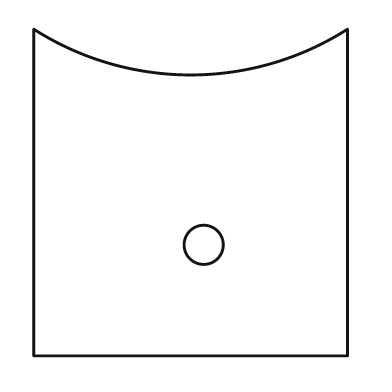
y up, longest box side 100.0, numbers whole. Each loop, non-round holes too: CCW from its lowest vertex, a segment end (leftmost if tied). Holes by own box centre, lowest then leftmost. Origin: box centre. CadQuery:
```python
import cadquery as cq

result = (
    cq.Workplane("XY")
    .moveTo(-48.0, -50.0)
    .lineTo(48.0, -50.0)
    .lineTo(48.0, 50.0)
    .threePointArc((0.0, 36.0), (-48.0, 50.0))
    .close()
    .moveTo(4.0, -16.0)
    .circle(6.0)
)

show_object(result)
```